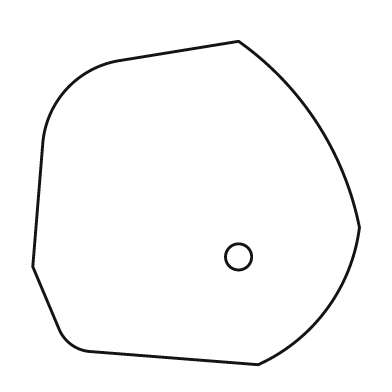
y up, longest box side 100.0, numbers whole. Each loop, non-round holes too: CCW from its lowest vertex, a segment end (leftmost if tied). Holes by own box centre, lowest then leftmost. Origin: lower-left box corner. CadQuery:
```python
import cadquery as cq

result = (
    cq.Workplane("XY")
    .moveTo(69.0, 0.0)
    .threePointArc((90.0, 17.0), (100.0, 42.0))
    .threePointArc((87.0, 74.0), (63.0, 99.0))
    .lineTo(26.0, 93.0)
    .threePointArc((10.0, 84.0), (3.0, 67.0))
    .lineTo(0.0, 30.0)
    .lineTo(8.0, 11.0)
    .threePointArc((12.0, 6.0), (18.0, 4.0))
    .close()
    .moveTo(63.0, 33.0)
    .circle(4.0)
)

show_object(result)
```